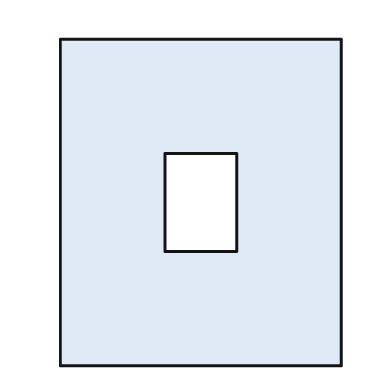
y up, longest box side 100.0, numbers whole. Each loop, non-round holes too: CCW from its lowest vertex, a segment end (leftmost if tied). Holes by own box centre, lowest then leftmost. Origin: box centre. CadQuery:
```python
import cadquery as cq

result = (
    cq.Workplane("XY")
    .moveTo(-43.0, -50.0)
    .lineTo(43.0, -50.0)
    .lineTo(43.0, 50.0)
    .lineTo(-43.0, 50.0)
    .close()
    .moveTo(-11.0, -15.0)
    .lineTo(11.0, -15.0)
    .lineTo(11.0, 15.0)
    .lineTo(-11.0, 15.0)
    .close()
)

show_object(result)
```